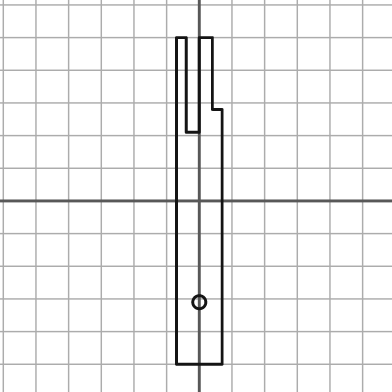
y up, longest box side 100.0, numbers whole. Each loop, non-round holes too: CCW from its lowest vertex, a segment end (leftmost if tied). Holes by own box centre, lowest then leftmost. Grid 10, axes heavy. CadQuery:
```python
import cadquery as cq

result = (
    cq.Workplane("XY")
    .moveTo(-7.0, -50.0)
    .lineTo(7.0, -50.0)
    .lineTo(7.0, 28.0)
    .lineTo(4.0, 28.0)
    .lineTo(4.0, 50.0)
    .lineTo(0.0, 50.0)
    .lineTo(0.0, 21.0)
    .lineTo(-4.0, 21.0)
    .lineTo(-4.0, 50.0)
    .lineTo(-7.0, 50.0)
    .close()
    .moveTo(0.0, -31.0)
    .circle(2.0)
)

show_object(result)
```